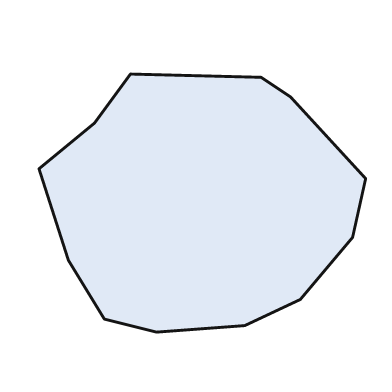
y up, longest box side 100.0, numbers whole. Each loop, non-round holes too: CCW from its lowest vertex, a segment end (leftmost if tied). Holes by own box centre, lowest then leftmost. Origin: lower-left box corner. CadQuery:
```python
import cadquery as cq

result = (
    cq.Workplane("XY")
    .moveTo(36.0, 0.0)
    .lineTo(63.0, 2.0)
    .lineTo(80.0, 10.0)
    .lineTo(96.0, 29.0)
    .lineTo(100.0, 47.0)
    .lineTo(77.0, 72.0)
    .lineTo(68.0, 78.0)
    .lineTo(28.0, 79.0)
    .lineTo(17.0, 64.0)
    .lineTo(0.0, 50.0)
    .lineTo(9.0, 22.0)
    .lineTo(20.0, 4.0)
    .close()
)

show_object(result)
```